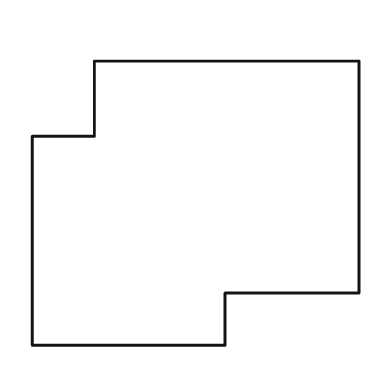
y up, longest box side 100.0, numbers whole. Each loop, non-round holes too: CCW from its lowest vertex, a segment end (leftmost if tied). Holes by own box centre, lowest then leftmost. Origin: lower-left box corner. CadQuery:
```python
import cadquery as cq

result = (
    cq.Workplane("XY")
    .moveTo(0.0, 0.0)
    .lineTo(59.0, 0.0)
    .lineTo(59.0, 16.0)
    .lineTo(100.0, 16.0)
    .lineTo(100.0, 87.0)
    .lineTo(19.0, 87.0)
    .lineTo(19.0, 64.0)
    .lineTo(0.0, 64.0)
    .close()
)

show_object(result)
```